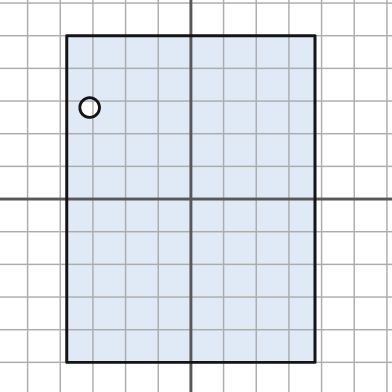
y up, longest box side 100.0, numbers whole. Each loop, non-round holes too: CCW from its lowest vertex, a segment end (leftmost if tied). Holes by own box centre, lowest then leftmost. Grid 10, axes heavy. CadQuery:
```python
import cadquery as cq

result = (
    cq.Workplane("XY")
    .moveTo(-38.0, -50.0)
    .lineTo(38.0, -50.0)
    .lineTo(38.0, 50.0)
    .lineTo(-38.0, 50.0)
    .close()
    .moveTo(-31.0, 28.0)
    .circle(3.0)
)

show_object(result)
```